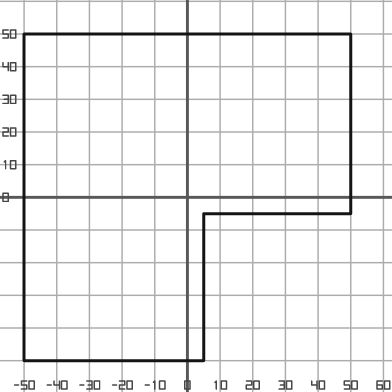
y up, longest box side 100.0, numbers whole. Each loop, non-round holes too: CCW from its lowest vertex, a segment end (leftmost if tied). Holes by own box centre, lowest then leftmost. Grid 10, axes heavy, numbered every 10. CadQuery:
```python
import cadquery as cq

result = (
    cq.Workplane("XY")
    .moveTo(-50.0, -50.0)
    .lineTo(5.0, -50.0)
    .lineTo(5.0, -5.0)
    .lineTo(50.0, -5.0)
    .lineTo(50.0, 50.0)
    .lineTo(-50.0, 50.0)
    .close()
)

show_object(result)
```